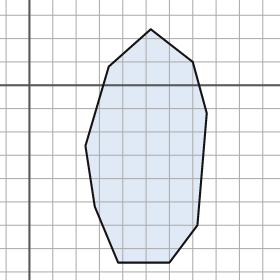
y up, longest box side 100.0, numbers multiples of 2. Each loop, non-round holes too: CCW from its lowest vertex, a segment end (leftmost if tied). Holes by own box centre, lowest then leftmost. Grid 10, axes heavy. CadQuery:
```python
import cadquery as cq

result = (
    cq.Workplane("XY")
    .moveTo(38.0, -76.0)
    .lineTo(60.0, -76.0)
    .lineTo(72.0, -60.0)
    .lineTo(76.0, -12.0)
    .lineTo(70.0, 10.0)
    .lineTo(52.0, 24.0)
    .lineTo(34.0, 8.0)
    .lineTo(24.0, -26.0)
    .lineTo(28.0, -52.0)
    .close()
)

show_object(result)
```